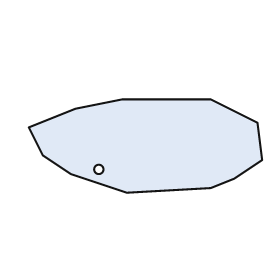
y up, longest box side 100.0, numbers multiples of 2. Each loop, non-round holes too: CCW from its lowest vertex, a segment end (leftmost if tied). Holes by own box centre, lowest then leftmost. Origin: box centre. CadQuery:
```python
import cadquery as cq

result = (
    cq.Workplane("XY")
    .moveTo(-8.0, -20.0)
    .lineTo(28.0, -18.0)
    .lineTo(38.0, -14.0)
    .lineTo(50.0, -6.0)
    .lineTo(48.0, 10.0)
    .lineTo(28.0, 20.0)
    .lineTo(-10.0, 20.0)
    .lineTo(-30.0, 16.0)
    .lineTo(-50.0, 8.0)
    .lineTo(-44.0, -4.0)
    .lineTo(-32.0, -12.0)
    .close()
    .moveTo(-20.0, -10.0)
    .circle(2.0)
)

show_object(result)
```